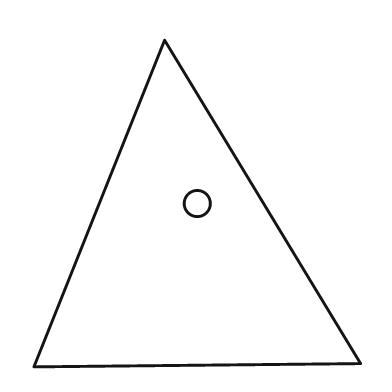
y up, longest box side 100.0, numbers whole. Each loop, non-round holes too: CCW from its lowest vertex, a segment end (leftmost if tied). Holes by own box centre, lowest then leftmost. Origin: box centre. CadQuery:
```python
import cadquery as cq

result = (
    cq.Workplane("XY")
    .moveTo(-50.0, -50.0)
    .lineTo(50.0, -49.0)
    .lineTo(-10.0, 50.0)
    .close()
    .moveTo(0.0, 0.0)
    .circle(4.0)
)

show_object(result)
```